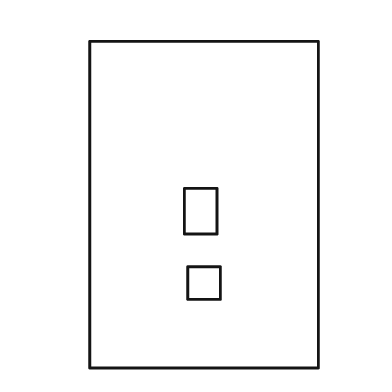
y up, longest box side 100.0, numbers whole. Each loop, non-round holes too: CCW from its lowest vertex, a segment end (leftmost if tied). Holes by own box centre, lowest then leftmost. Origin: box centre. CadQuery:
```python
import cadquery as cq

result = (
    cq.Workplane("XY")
    .moveTo(-35.0, -50.0)
    .lineTo(35.0, -50.0)
    .lineTo(35.0, 50.0)
    .lineTo(-35.0, 50.0)
    .close()
    .moveTo(-5.0, -29.0)
    .lineTo(5.0, -29.0)
    .lineTo(5.0, -19.0)
    .lineTo(-5.0, -19.0)
    .close()
    .moveTo(-6.0, -9.0)
    .lineTo(4.0, -9.0)
    .lineTo(4.0, 5.0)
    .lineTo(-6.0, 5.0)
    .close()
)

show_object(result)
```